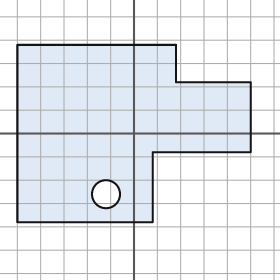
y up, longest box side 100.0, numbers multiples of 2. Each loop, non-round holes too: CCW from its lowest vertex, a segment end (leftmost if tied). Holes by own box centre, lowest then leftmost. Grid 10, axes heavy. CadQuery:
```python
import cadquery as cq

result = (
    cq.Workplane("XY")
    .moveTo(-50.0, -38.0)
    .lineTo(8.0, -38.0)
    .lineTo(8.0, -8.0)
    .lineTo(50.0, -8.0)
    .lineTo(50.0, 22.0)
    .lineTo(18.0, 22.0)
    .lineTo(18.0, 38.0)
    .lineTo(-50.0, 38.0)
    .close()
    .moveTo(-12.0, -26.0)
    .circle(6.0)
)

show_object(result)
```